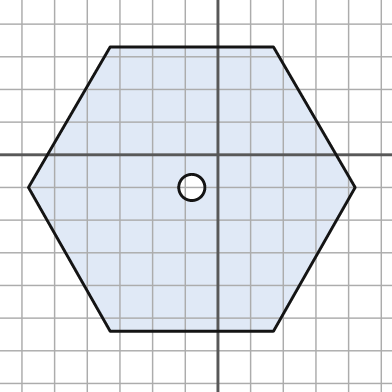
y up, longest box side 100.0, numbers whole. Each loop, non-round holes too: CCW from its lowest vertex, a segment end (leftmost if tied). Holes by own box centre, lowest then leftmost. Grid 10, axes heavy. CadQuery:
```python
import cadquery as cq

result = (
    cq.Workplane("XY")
    .moveTo(-33.0, -54.0)
    .lineTo(17.0, -54.0)
    .lineTo(42.0, -10.0)
    .lineTo(17.0, 33.0)
    .lineTo(-33.0, 33.0)
    .lineTo(-58.0, -10.0)
    .close()
    .moveTo(-8.0, -10.0)
    .circle(4.0)
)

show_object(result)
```